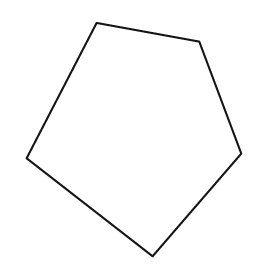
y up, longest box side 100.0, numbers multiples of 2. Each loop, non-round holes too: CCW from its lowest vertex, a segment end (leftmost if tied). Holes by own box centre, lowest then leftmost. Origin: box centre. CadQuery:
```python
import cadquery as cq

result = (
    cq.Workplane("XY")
    .moveTo(8.0, -50.0)
    .lineTo(46.0, -6.0)
    .lineTo(28.0, 42.0)
    .lineTo(-16.0, 50.0)
    .lineTo(-46.0, -8.0)
    .close()
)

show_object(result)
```